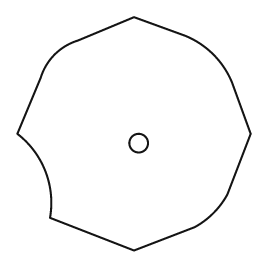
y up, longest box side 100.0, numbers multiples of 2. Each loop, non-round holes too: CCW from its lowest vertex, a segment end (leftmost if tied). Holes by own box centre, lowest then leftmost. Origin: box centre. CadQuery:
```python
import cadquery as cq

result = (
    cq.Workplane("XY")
    .moveTo(0.0, -50.0)
    .lineTo(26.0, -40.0)
    .threePointArc((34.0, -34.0), (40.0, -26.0))
    .lineTo(50.0, 0.0)
    .lineTo(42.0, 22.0)
    .threePointArc((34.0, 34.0), (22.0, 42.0))
    .lineTo(0.0, 50.0)
    .lineTo(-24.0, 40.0)
    .threePointArc((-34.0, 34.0), (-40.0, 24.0))
    .lineTo(-50.0, 0.0)
    .threePointArc((-38.0, -16.0), (-36.0, -36.0))
    .close()
    .moveTo(2.0, -4.0)
    .circle(4.0)
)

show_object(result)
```